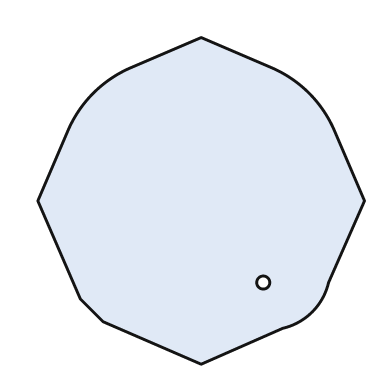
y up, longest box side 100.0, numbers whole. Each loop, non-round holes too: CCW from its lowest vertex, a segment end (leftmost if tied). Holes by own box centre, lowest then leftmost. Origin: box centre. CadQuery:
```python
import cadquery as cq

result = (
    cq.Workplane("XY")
    .moveTo(0.0, -50.0)
    .lineTo(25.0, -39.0)
    .threePointArc((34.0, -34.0), (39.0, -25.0))
    .lineTo(50.0, 0.0)
    .lineTo(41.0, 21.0)
    .threePointArc((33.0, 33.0), (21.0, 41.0))
    .lineTo(0.0, 50.0)
    .lineTo(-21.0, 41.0)
    .threePointArc((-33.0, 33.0), (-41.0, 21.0))
    .lineTo(-50.0, 0.0)
    .lineTo(-37.0, -30.0)
    .lineTo(-30.0, -37.0)
    .close()
    .moveTo(19.0, -25.0)
    .circle(2.0)
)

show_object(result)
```